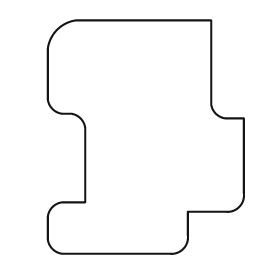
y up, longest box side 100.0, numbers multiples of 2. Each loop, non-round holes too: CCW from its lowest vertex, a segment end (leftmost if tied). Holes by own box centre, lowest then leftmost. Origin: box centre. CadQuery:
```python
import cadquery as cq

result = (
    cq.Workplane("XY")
    .moveTo(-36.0, -50.0)
    .lineTo(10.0, -50.0)
    .threePointArc((16.0, -48.0), (18.0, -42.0))
    .lineTo(18.0, -32.0)
    .lineTo(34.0, -32.0)
    .threePointArc((40.0, -30.0), (42.0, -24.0))
    .lineTo(42.0, 8.0)
    .lineTo(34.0, 8.0)
    .threePointArc((30.0, 10.0), (28.0, 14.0))
    .lineTo(28.0, 50.0)
    .lineTo(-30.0, 50.0)
    .threePointArc((-38.0, 46.0), (-42.0, 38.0))
    .lineTo(-42.0, 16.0)
    .threePointArc((-40.0, 12.0), (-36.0, 10.0))
    .lineTo(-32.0, 10.0)
    .threePointArc((-28.0, 8.0), (-26.0, 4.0))
    .lineTo(-26.0, -28.0)
    .lineTo(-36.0, -28.0)
    .threePointArc((-40.0, -30.0), (-42.0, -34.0))
    .lineTo(-42.0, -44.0)
    .threePointArc((-40.0, -48.0), (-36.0, -50.0))
    .close()
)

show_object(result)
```